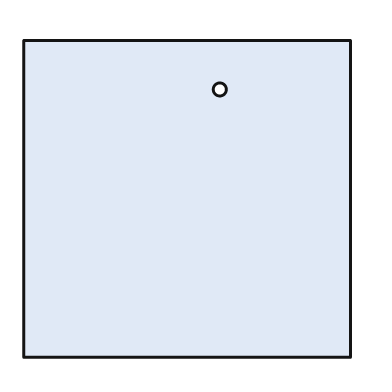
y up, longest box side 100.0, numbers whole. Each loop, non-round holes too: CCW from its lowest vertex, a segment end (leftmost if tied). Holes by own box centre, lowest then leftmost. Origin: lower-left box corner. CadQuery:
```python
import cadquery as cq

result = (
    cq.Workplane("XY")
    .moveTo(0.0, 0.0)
    .lineTo(100.0, 0.0)
    .lineTo(100.0, 97.0)
    .lineTo(0.0, 97.0)
    .close()
    .moveTo(60.0, 82.0)
    .circle(2.0)
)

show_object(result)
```